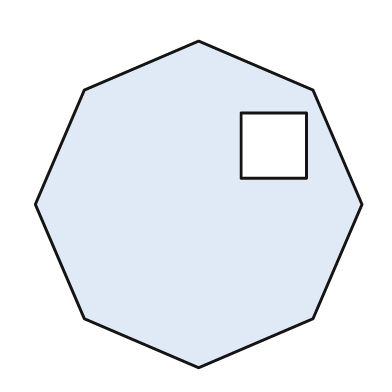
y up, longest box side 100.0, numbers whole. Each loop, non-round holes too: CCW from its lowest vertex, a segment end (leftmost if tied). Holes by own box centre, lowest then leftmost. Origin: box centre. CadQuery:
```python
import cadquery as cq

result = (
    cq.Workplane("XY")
    .moveTo(0.0, -50.0)
    .lineTo(35.0, -35.0)
    .lineTo(50.0, 0.0)
    .lineTo(35.0, 35.0)
    .lineTo(0.0, 50.0)
    .lineTo(-35.0, 35.0)
    .lineTo(-50.0, 0.0)
    .lineTo(-35.0, -35.0)
    .close()
    .moveTo(13.0, 8.0)
    .lineTo(33.0, 8.0)
    .lineTo(33.0, 28.0)
    .lineTo(13.0, 28.0)
    .close()
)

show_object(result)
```